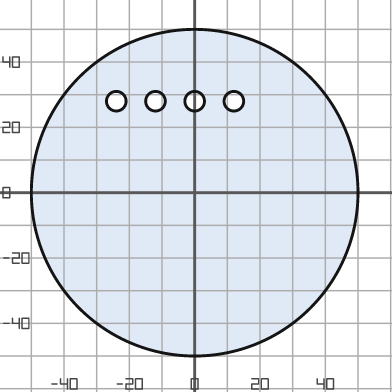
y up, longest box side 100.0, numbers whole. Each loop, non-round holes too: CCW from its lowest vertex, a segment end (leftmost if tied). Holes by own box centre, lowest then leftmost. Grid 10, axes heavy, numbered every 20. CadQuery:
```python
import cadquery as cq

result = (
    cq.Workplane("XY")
    .moveTo(0.0, 0.0)
    .circle(50.0)
    .moveTo(-24.0, 28.0)
    .circle(3.0)
    .moveTo(-12.0, 28.0)
    .circle(3.0)
    .moveTo(0.0, 28.0)
    .circle(3.0)
    .moveTo(12.0, 28.0)
    .circle(3.0)
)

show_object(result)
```